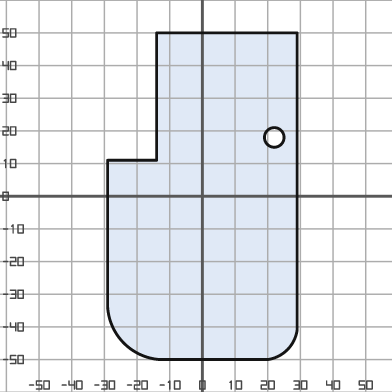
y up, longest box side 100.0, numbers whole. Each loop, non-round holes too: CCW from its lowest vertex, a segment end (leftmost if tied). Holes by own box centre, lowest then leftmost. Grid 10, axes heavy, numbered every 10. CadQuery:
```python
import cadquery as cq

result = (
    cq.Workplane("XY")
    .moveTo(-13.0, -50.0)
    .lineTo(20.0, -50.0)
    .threePointArc((26.0, -47.0), (29.0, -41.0))
    .lineTo(29.0, 50.0)
    .lineTo(-14.0, 50.0)
    .lineTo(-14.0, 11.0)
    .lineTo(-29.0, 11.0)
    .lineTo(-29.0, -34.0)
    .threePointArc((-24.0, -45.0), (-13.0, -50.0))
    .close()
    .moveTo(22.0, 18.0)
    .circle(3.0)
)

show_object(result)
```